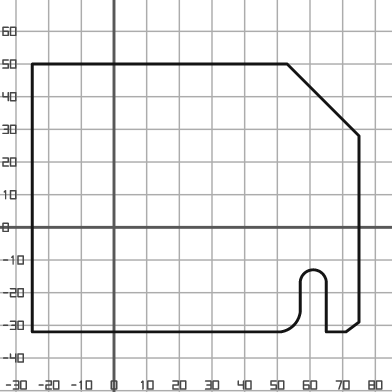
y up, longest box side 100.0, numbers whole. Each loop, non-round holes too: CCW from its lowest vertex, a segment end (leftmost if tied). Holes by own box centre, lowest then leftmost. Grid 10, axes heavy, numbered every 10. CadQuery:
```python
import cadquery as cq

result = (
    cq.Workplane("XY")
    .moveTo(-25.0, -32.0)
    .lineTo(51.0, -32.0)
    .threePointArc((55.0, -30.0), (57.0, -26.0))
    .lineTo(57.0, -17.0)
    .threePointArc((61.0, -13.0), (65.0, -17.0))
    .lineTo(65.0, -32.0)
    .lineTo(71.0, -32.0)
    .lineTo(75.0, -29.0)
    .lineTo(75.0, 28.0)
    .lineTo(53.0, 50.0)
    .lineTo(-25.0, 50.0)
    .close()
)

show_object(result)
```